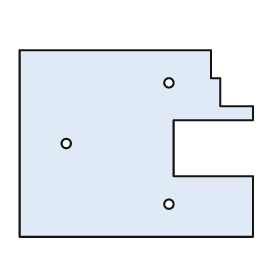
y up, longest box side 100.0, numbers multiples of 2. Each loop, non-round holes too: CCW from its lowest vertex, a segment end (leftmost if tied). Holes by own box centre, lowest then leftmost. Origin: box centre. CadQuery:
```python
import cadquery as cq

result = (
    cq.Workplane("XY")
    .moveTo(-50.0, -40.0)
    .lineTo(50.0, -40.0)
    .lineTo(50.0, -14.0)
    .lineTo(16.0, -14.0)
    .lineTo(16.0, 10.0)
    .lineTo(50.0, 10.0)
    .lineTo(50.0, 16.0)
    .lineTo(36.0, 16.0)
    .lineTo(36.0, 28.0)
    .lineTo(32.0, 28.0)
    .lineTo(32.0, 40.0)
    .lineTo(-50.0, 40.0)
    .close()
    .moveTo(14.0, -26.0)
    .circle(2.0)
    .moveTo(-30.0, 0.0)
    .circle(2.0)
    .moveTo(14.0, 26.0)
    .circle(2.0)
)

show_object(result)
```